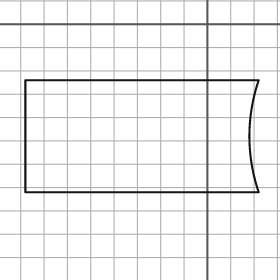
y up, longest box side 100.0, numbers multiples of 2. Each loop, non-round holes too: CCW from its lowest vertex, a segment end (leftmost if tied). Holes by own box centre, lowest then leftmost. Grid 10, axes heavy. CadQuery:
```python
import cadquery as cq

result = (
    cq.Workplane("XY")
    .moveTo(-78.0, -72.0)
    .lineTo(22.0, -72.0)
    .threePointArc((18.0, -48.0), (22.0, -24.0))
    .lineTo(-78.0, -24.0)
    .close()
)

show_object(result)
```